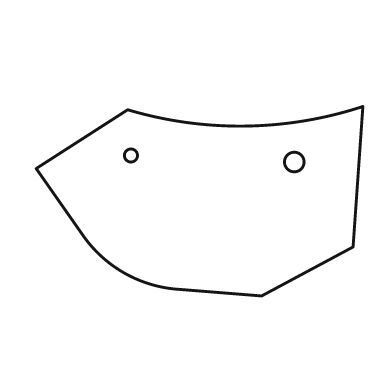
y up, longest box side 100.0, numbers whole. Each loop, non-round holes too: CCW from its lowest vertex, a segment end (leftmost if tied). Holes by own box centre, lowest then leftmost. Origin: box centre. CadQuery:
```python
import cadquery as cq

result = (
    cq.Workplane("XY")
    .moveTo(19.0, -29.0)
    .lineTo(47.0, -14.0)
    .lineTo(50.0, 29.0)
    .threePointArc((14.0, 23.0), (-22.0, 28.0))
    .lineTo(-50.0, 10.0)
    .lineTo(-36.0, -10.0)
    .threePointArc((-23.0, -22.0), (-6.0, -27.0))
    .close()
    .moveTo(29.0, 12.0)
    .circle(3.0)
    .moveTo(-21.0, 14.0)
    .circle(2.0)
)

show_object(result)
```